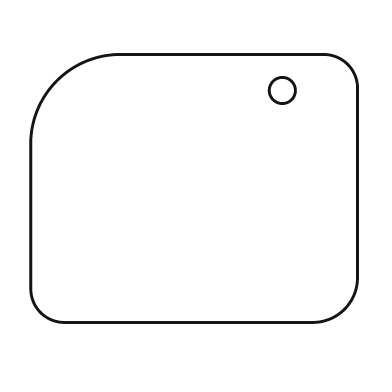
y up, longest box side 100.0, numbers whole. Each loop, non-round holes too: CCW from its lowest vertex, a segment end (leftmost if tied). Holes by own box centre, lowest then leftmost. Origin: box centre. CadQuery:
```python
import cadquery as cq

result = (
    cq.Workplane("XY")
    .moveTo(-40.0, -41.0)
    .lineTo(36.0, -41.0)
    .threePointArc((46.0, -37.0), (50.0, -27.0))
    .lineTo(50.0, 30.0)
    .threePointArc((47.0, 38.0), (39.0, 41.0))
    .lineTo(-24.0, 41.0)
    .threePointArc((-42.0, 33.0), (-50.0, 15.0))
    .lineTo(-50.0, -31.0)
    .threePointArc((-47.0, -38.0), (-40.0, -41.0))
    .close()
    .moveTo(27.0, 30.0)
    .circle(4.0)
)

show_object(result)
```